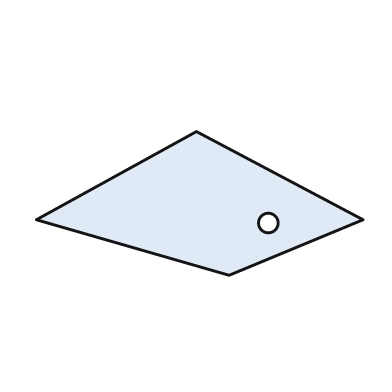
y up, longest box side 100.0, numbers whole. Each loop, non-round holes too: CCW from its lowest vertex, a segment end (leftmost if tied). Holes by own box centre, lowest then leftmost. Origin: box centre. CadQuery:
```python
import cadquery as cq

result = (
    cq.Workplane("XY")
    .moveTo(9.0, -22.0)
    .lineTo(50.0, -5.0)
    .lineTo(-1.0, 22.0)
    .lineTo(-50.0, -5.0)
    .close()
    .moveTo(21.0, -6.0)
    .circle(3.0)
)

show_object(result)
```